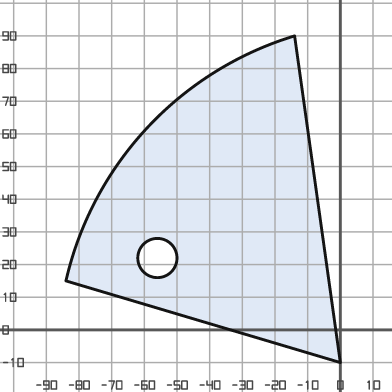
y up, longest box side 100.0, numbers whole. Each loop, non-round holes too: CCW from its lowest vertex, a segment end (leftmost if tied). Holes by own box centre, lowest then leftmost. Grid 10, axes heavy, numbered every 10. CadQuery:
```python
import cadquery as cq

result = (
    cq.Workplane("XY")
    .moveTo(0.0, -10.0)
    .lineTo(-14.0, 90.0)
    .threePointArc((-59.0, 62.0), (-84.0, 15.0))
    .close()
    .moveTo(-56.0, 22.0)
    .circle(6.0)
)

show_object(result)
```